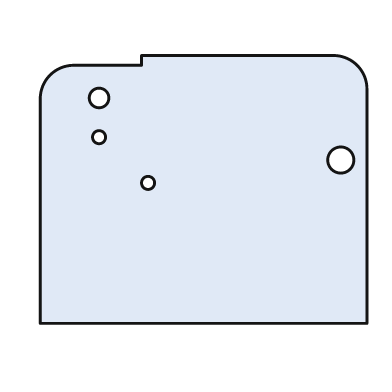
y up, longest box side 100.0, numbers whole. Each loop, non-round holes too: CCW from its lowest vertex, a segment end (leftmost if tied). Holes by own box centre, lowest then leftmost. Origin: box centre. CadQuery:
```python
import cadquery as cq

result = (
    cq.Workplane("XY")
    .moveTo(-50.0, -41.0)
    .lineTo(50.0, -41.0)
    .lineTo(50.0, 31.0)
    .threePointArc((47.0, 38.0), (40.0, 41.0))
    .lineTo(-19.0, 41.0)
    .lineTo(-19.0, 38.0)
    .lineTo(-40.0, 38.0)
    .threePointArc((-47.0, 35.0), (-50.0, 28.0))
    .close()
    .moveTo(-17.0, 2.0)
    .circle(2.0)
    .moveTo(42.0, 9.0)
    .circle(4.0)
    .moveTo(-32.0, 16.0)
    .circle(2.0)
    .moveTo(-32.0, 28.0)
    .circle(3.0)
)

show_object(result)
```